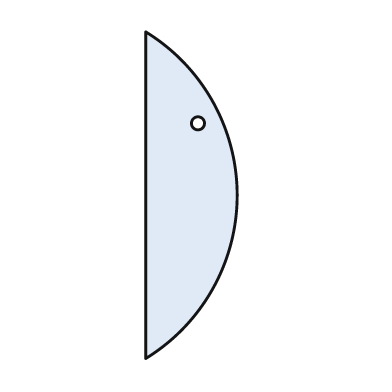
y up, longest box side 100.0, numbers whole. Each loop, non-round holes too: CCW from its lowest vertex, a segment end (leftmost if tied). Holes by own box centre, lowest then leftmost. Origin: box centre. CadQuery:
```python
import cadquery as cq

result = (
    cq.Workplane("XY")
    .moveTo(-14.0, -50.0)
    .threePointArc((14.0, 0.0), (-14.0, 50.0))
    .close()
    .moveTo(2.0, 22.0)
    .circle(2.0)
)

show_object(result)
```